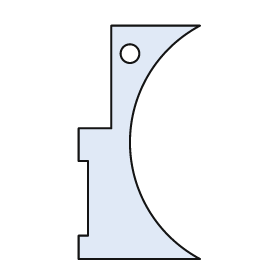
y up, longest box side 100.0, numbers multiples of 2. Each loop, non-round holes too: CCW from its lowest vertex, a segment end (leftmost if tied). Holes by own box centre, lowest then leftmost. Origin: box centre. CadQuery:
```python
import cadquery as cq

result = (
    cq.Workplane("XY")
    .moveTo(-26.0, -50.0)
    .lineTo(26.0, -50.0)
    .threePointArc((-4.0, 0.0), (26.0, 50.0))
    .lineTo(-12.0, 50.0)
    .lineTo(-12.0, 6.0)
    .lineTo(-26.0, 6.0)
    .lineTo(-26.0, -8.0)
    .lineTo(-22.0, -8.0)
    .lineTo(-22.0, -40.0)
    .lineTo(-26.0, -40.0)
    .close()
    .moveTo(-4.0, 38.0)
    .circle(4.0)
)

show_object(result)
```